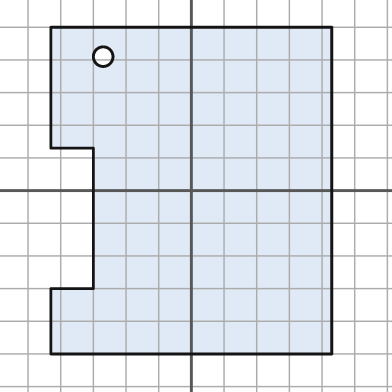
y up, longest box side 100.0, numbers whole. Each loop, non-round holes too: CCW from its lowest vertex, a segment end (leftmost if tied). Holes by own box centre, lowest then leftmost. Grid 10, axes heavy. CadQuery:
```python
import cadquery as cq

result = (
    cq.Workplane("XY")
    .moveTo(-43.0, -50.0)
    .lineTo(43.0, -50.0)
    .lineTo(43.0, 50.0)
    .lineTo(-43.0, 50.0)
    .lineTo(-43.0, 13.0)
    .lineTo(-30.0, 13.0)
    .lineTo(-30.0, -30.0)
    .lineTo(-43.0, -30.0)
    .close()
    .moveTo(-27.0, 41.0)
    .circle(3.0)
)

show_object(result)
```